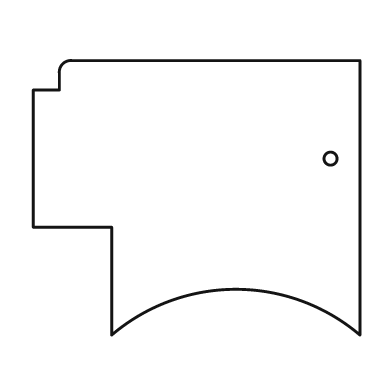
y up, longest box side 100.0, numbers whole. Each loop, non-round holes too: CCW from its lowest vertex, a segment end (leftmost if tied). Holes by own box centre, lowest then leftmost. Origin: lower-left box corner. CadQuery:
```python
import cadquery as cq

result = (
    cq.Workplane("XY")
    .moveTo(24.0, 0.0)
    .threePointArc((62.0, 14.0), (100.0, 0.0))
    .lineTo(100.0, 84.0)
    .lineTo(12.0, 84.0)
    .threePointArc((9.0, 83.0), (8.0, 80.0))
    .lineTo(8.0, 75.0)
    .lineTo(0.0, 75.0)
    .lineTo(0.0, 33.0)
    .lineTo(24.0, 33.0)
    .close()
    .moveTo(91.0, 54.0)
    .circle(2.0)
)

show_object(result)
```